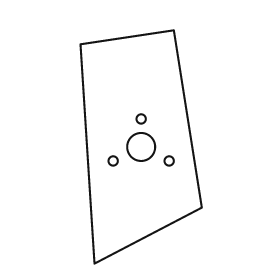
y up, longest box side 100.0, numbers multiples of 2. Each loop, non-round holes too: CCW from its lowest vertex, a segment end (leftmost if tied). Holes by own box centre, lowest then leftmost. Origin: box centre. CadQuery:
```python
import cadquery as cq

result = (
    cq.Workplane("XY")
    .moveTo(-20.0, -50.0)
    .lineTo(26.0, -26.0)
    .lineTo(14.0, 50.0)
    .lineTo(-26.0, 44.0)
    .close()
    .moveTo(-12.0, -6.0)
    .circle(2.0)
    .moveTo(12.0, -6.0)
    .circle(2.0)
    .moveTo(0.0, 0.0)
    .circle(6.0)
    .moveTo(0.0, 12.0)
    .circle(2.0)
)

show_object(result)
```